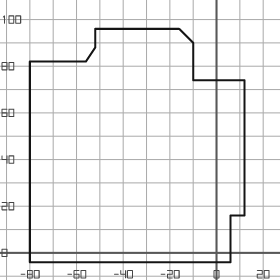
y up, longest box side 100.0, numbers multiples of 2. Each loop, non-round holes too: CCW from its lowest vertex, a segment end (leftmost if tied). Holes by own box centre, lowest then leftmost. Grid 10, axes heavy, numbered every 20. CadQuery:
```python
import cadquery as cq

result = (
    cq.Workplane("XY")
    .moveTo(-80.0, -4.0)
    .lineTo(6.0, -4.0)
    .lineTo(6.0, 16.0)
    .lineTo(12.0, 16.0)
    .lineTo(12.0, 74.0)
    .lineTo(-10.0, 74.0)
    .lineTo(-10.0, 90.0)
    .lineTo(-16.0, 96.0)
    .lineTo(-52.0, 96.0)
    .lineTo(-52.0, 88.0)
    .lineTo(-56.0, 82.0)
    .lineTo(-80.0, 82.0)
    .close()
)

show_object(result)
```